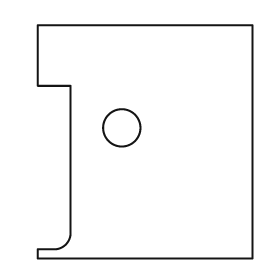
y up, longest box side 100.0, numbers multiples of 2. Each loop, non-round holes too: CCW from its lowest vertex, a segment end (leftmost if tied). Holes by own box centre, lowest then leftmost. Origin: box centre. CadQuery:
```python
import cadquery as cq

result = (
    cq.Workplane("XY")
    .moveTo(-46.0, -50.0)
    .lineTo(46.0, -50.0)
    .lineTo(46.0, 50.0)
    .lineTo(-46.0, 50.0)
    .lineTo(-46.0, 24.0)
    .lineTo(-32.0, 24.0)
    .lineTo(-32.0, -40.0)
    .threePointArc((-34.0, -44.0), (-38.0, -46.0))
    .lineTo(-46.0, -46.0)
    .close()
    .moveTo(-10.0, 6.0)
    .circle(8.0)
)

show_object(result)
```